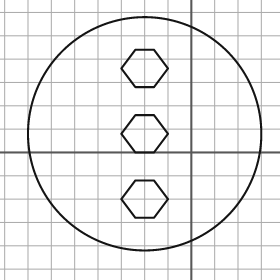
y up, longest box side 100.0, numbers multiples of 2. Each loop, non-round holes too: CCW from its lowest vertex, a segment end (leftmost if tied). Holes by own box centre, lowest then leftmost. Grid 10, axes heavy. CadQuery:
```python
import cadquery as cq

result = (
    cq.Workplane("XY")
    .moveTo(-20.0, 8.0)
    .circle(50.0)
    .moveTo(-24.0, -28.0)
    .lineTo(-16.0, -28.0)
    .lineTo(-10.0, -20.0)
    .lineTo(-16.0, -12.0)
    .lineTo(-24.0, -12.0)
    .lineTo(-30.0, -20.0)
    .close()
    .moveTo(-24.0, 0.0)
    .lineTo(-16.0, 0.0)
    .lineTo(-10.0, 8.0)
    .lineTo(-16.0, 16.0)
    .lineTo(-24.0, 16.0)
    .lineTo(-30.0, 8.0)
    .close()
    .moveTo(-24.0, 28.0)
    .lineTo(-16.0, 28.0)
    .lineTo(-10.0, 36.0)
    .lineTo(-16.0, 44.0)
    .lineTo(-24.0, 44.0)
    .lineTo(-30.0, 36.0)
    .close()
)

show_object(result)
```